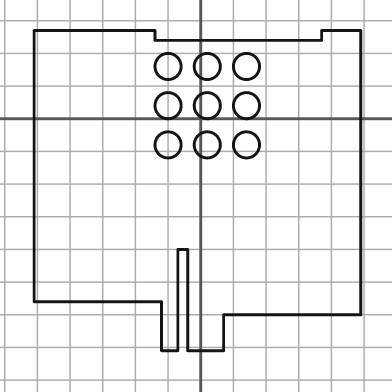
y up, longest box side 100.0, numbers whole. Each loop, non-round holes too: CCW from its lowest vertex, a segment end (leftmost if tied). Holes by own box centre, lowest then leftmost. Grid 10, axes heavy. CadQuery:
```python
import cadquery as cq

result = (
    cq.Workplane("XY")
    .moveTo(-12.0, -71.0)
    .lineTo(-7.0, -71.0)
    .lineTo(-7.0, -40.0)
    .lineTo(-4.0, -40.0)
    .lineTo(-4.0, -71.0)
    .lineTo(7.0, -71.0)
    .lineTo(7.0, -60.0)
    .lineTo(49.0, -60.0)
    .lineTo(49.0, 27.0)
    .lineTo(37.0, 27.0)
    .lineTo(37.0, 24.0)
    .lineTo(-14.0, 24.0)
    .lineTo(-14.0, 27.0)
    .lineTo(-51.0, 27.0)
    .lineTo(-51.0, -56.0)
    .lineTo(-12.0, -56.0)
    .close()
    .moveTo(-10.0, -8.0)
    .circle(4.0)
    .moveTo(2.0, -8.0)
    .circle(4.0)
    .moveTo(14.0, -8.0)
    .circle(4.0)
    .moveTo(-10.0, 4.0)
    .circle(4.0)
    .moveTo(2.0, 4.0)
    .circle(4.0)
    .moveTo(14.0, 4.0)
    .circle(4.0)
    .moveTo(-10.0, 16.0)
    .circle(4.0)
    .moveTo(2.0, 16.0)
    .circle(4.0)
    .moveTo(14.0, 16.0)
    .circle(4.0)
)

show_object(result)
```